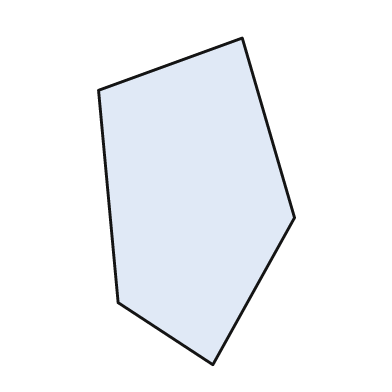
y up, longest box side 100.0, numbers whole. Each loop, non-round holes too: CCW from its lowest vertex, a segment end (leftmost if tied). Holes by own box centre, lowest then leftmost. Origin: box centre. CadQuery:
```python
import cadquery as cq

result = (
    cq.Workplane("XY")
    .moveTo(5.0, -50.0)
    .lineTo(30.0, -5.0)
    .lineTo(14.0, 50.0)
    .lineTo(-30.0, 34.0)
    .lineTo(-24.0, -31.0)
    .close()
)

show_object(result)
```